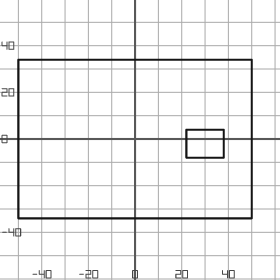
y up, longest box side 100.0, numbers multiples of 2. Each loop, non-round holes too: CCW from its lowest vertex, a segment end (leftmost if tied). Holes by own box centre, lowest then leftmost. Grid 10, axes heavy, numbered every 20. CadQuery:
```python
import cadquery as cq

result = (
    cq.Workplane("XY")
    .moveTo(-50.0, -34.0)
    .lineTo(50.0, -34.0)
    .lineTo(50.0, 34.0)
    .lineTo(-50.0, 34.0)
    .close()
    .moveTo(22.0, -8.0)
    .lineTo(38.0, -8.0)
    .lineTo(38.0, 4.0)
    .lineTo(22.0, 4.0)
    .close()
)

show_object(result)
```